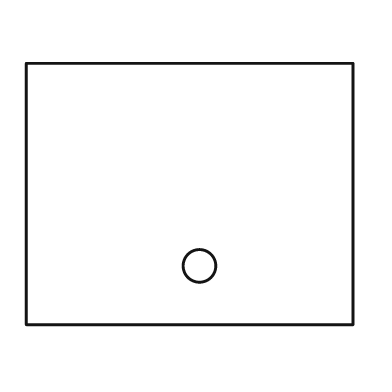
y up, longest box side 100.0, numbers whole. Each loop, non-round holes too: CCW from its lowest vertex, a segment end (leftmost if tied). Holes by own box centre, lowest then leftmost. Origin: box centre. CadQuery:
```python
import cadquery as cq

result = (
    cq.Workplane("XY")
    .moveTo(-50.0, -40.0)
    .lineTo(50.0, -40.0)
    .lineTo(50.0, 40.0)
    .lineTo(-50.0, 40.0)
    .close()
    .moveTo(3.0, -22.0)
    .circle(5.0)
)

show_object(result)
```